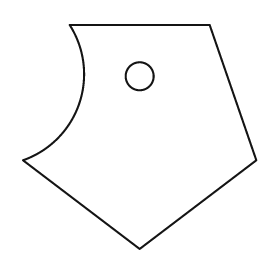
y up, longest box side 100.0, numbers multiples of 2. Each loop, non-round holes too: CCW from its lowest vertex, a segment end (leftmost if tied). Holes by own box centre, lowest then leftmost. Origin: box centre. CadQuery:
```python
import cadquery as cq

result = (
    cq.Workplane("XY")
    .moveTo(0.0, -48.0)
    .lineTo(50.0, -10.0)
    .lineTo(30.0, 48.0)
    .lineTo(-30.0, 48.0)
    .threePointArc((-26.0, 14.0), (-50.0, -10.0))
    .close()
    .moveTo(0.0, 26.0)
    .circle(6.0)
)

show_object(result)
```